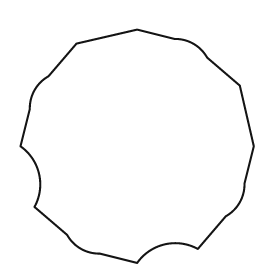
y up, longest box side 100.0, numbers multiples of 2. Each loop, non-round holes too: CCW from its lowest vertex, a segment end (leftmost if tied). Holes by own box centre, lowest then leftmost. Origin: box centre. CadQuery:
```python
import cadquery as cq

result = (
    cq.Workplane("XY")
    .moveTo(0.0, -50.0)
    .threePointArc((12.0, -42.0), (26.0, -44.0))
    .lineTo(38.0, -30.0)
    .threePointArc((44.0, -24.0), (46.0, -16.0))
    .lineTo(50.0, 0.0)
    .lineTo(44.0, 26.0)
    .lineTo(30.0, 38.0)
    .threePointArc((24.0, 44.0), (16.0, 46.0))
    .lineTo(0.0, 50.0)
    .lineTo(-26.0, 44.0)
    .lineTo(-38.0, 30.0)
    .threePointArc((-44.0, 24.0), (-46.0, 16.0))
    .lineTo(-50.0, 0.0)
    .threePointArc((-42.0, -12.0), (-44.0, -26.0))
    .lineTo(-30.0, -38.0)
    .threePointArc((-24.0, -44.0), (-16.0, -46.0))
    .close()
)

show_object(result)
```